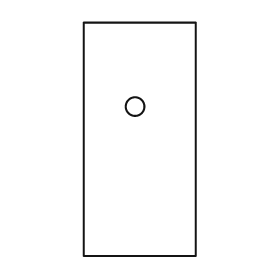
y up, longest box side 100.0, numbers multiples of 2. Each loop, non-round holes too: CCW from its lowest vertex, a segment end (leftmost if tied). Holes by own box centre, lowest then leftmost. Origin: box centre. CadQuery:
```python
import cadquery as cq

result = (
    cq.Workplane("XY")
    .moveTo(-24.0, -50.0)
    .lineTo(24.0, -50.0)
    .lineTo(24.0, 50.0)
    .lineTo(-24.0, 50.0)
    .close()
    .moveTo(-2.0, 14.0)
    .circle(4.0)
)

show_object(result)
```